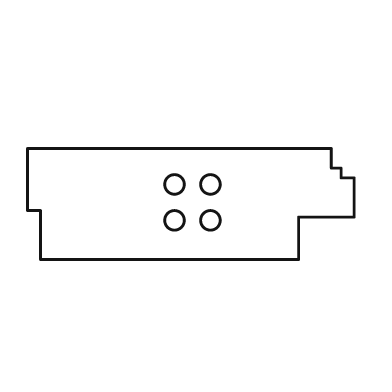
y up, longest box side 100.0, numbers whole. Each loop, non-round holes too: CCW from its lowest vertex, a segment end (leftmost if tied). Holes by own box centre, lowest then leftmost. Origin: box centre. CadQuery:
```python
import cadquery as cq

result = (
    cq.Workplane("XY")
    .moveTo(-46.0, -17.0)
    .lineTo(33.0, -17.0)
    .lineTo(33.0, -4.0)
    .lineTo(50.0, -4.0)
    .lineTo(50.0, 8.0)
    .lineTo(46.0, 8.0)
    .lineTo(46.0, 11.0)
    .lineTo(43.0, 11.0)
    .lineTo(43.0, 17.0)
    .lineTo(-50.0, 17.0)
    .lineTo(-50.0, -2.0)
    .lineTo(-46.0, -2.0)
    .close()
    .moveTo(-5.0, -5.0)
    .circle(3.0)
    .moveTo(6.0, -5.0)
    .circle(3.0)
    .moveTo(-5.0, 6.0)
    .circle(3.0)
    .moveTo(6.0, 6.0)
    .circle(3.0)
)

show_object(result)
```